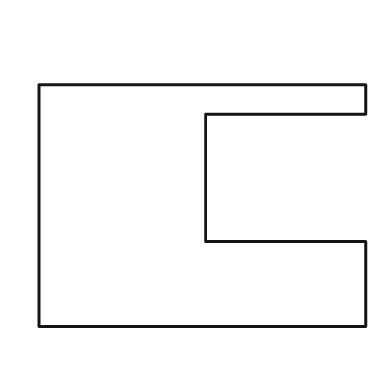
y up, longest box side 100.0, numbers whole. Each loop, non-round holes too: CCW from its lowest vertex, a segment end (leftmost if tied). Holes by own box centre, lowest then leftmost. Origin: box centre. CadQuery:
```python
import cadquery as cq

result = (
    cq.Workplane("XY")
    .moveTo(-50.0, -37.0)
    .lineTo(50.0, -37.0)
    .lineTo(50.0, -11.0)
    .lineTo(1.0, -11.0)
    .lineTo(1.0, 28.0)
    .lineTo(50.0, 28.0)
    .lineTo(50.0, 37.0)
    .lineTo(-50.0, 37.0)
    .close()
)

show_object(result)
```